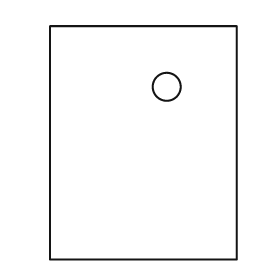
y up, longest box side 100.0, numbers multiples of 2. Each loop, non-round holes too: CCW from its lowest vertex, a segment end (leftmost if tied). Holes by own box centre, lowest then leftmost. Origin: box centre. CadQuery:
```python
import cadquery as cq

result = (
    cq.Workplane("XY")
    .moveTo(-40.0, -50.0)
    .lineTo(40.0, -50.0)
    .lineTo(40.0, 50.0)
    .lineTo(-40.0, 50.0)
    .close()
    .moveTo(10.0, 24.0)
    .circle(6.0)
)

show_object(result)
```